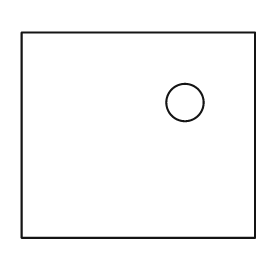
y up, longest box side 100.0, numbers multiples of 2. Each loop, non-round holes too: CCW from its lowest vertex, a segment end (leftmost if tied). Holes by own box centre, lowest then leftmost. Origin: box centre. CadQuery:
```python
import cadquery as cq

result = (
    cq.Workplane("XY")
    .moveTo(-50.0, -44.0)
    .lineTo(50.0, -44.0)
    .lineTo(50.0, 44.0)
    .lineTo(-50.0, 44.0)
    .close()
    .moveTo(20.0, 14.0)
    .circle(8.0)
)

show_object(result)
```